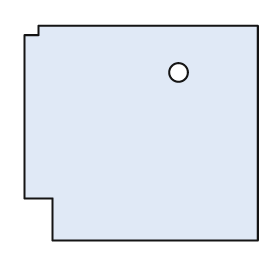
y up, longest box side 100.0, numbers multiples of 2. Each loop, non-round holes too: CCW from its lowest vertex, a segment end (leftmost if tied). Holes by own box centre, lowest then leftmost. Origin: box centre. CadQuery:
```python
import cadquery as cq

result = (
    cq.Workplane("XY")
    .moveTo(-38.0, -46.0)
    .lineTo(50.0, -46.0)
    .lineTo(50.0, 46.0)
    .lineTo(-44.0, 46.0)
    .lineTo(-44.0, 42.0)
    .lineTo(-50.0, 42.0)
    .lineTo(-50.0, -28.0)
    .lineTo(-38.0, -28.0)
    .close()
    .moveTo(16.0, 26.0)
    .circle(4.0)
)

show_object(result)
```